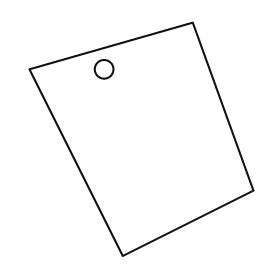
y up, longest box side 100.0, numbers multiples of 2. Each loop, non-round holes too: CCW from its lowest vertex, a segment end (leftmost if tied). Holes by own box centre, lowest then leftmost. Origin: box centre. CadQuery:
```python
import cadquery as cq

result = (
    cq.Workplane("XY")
    .moveTo(-8.0, -50.0)
    .lineTo(48.0, -22.0)
    .lineTo(22.0, 50.0)
    .lineTo(-48.0, 30.0)
    .close()
    .moveTo(-16.0, 30.0)
    .circle(4.0)
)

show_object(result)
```